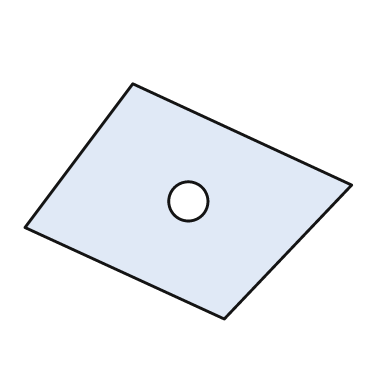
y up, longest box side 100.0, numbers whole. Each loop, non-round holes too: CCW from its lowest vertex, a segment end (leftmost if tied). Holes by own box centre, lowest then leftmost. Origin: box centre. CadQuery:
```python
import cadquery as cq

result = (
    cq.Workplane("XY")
    .moveTo(11.0, -36.0)
    .lineTo(50.0, 5.0)
    .lineTo(-17.0, 36.0)
    .lineTo(-50.0, -8.0)
    .close()
    .moveTo(0.0, 0.0)
    .circle(6.0)
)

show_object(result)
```